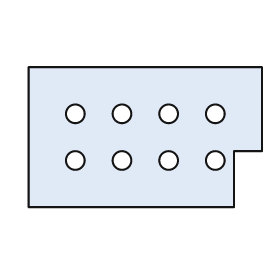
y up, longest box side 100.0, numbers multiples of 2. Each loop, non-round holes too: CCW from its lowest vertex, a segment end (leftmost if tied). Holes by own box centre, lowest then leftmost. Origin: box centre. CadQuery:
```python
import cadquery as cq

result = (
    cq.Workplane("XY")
    .moveTo(-50.0, -30.0)
    .lineTo(38.0, -30.0)
    .lineTo(38.0, -6.0)
    .lineTo(50.0, -6.0)
    .lineTo(50.0, 30.0)
    .lineTo(-50.0, 30.0)
    .close()
    .moveTo(-30.0, -10.0)
    .circle(4.0)
    .moveTo(-10.0, -10.0)
    .circle(4.0)
    .moveTo(10.0, -10.0)
    .circle(4.0)
    .moveTo(30.0, -10.0)
    .circle(4.0)
    .moveTo(-30.0, 10.0)
    .circle(4.0)
    .moveTo(-10.0, 10.0)
    .circle(4.0)
    .moveTo(10.0, 10.0)
    .circle(4.0)
    .moveTo(30.0, 10.0)
    .circle(4.0)
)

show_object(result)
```